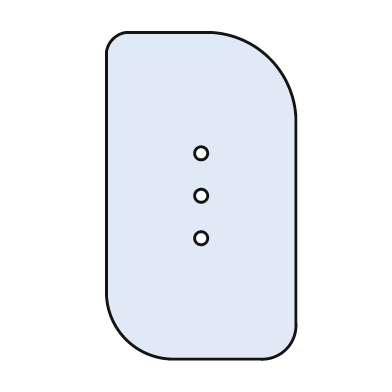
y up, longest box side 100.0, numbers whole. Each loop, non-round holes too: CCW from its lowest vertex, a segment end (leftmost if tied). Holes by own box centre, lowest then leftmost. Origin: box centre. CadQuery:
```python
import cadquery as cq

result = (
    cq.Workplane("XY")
    .moveTo(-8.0, -50.0)
    .lineTo(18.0, -50.0)
    .threePointArc((26.0, -47.0), (29.0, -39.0))
    .lineTo(29.0, 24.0)
    .threePointArc((21.0, 42.0), (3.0, 50.0))
    .lineTo(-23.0, 50.0)
    .threePointArc((-27.0, 48.0), (-29.0, 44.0))
    .lineTo(-29.0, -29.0)
    .threePointArc((-23.0, -44.0), (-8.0, -50.0))
    .close()
    .moveTo(0.0, -13.0)
    .circle(2.0)
    .moveTo(0.0, 0.0)
    .circle(2.0)
    .moveTo(0.0, 13.0)
    .circle(2.0)
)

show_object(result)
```